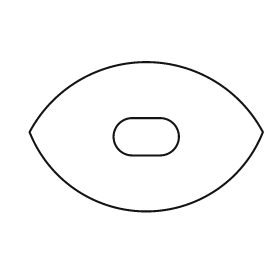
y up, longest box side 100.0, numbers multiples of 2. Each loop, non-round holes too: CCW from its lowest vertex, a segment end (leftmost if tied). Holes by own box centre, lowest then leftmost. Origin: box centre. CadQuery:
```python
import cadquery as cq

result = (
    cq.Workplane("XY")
    .moveTo(-50.0, 2.0)
    .threePointArc((0.0, -32.0), (50.0, 2.0))
    .threePointArc((0.0, 32.0), (-50.0, 2.0))
    .close()
    .moveTo(-6.0, -8.0)
    .lineTo(6.0, -8.0)
    .threePointArc((14.0, 0.0), (6.0, 8.0))
    .lineTo(-6.0, 8.0)
    .threePointArc((-14.0, 0.0), (-6.0, -8.0))
    .close()
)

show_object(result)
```